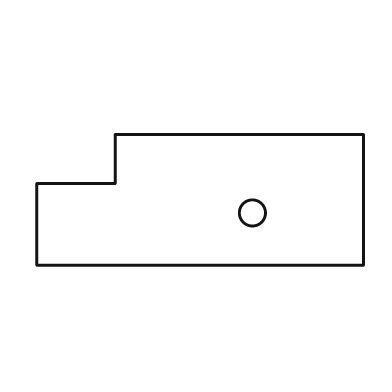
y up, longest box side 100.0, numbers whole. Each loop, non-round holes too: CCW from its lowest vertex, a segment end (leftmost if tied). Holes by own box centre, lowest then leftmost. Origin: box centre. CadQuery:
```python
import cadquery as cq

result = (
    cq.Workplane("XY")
    .moveTo(-50.0, -20.0)
    .lineTo(50.0, -20.0)
    .lineTo(50.0, 20.0)
    .lineTo(-26.0, 20.0)
    .lineTo(-26.0, 5.0)
    .lineTo(-50.0, 5.0)
    .close()
    .moveTo(16.0, -4.0)
    .circle(4.0)
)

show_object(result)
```